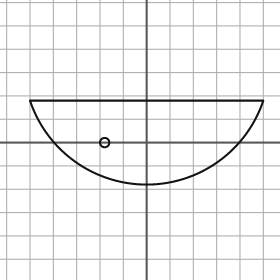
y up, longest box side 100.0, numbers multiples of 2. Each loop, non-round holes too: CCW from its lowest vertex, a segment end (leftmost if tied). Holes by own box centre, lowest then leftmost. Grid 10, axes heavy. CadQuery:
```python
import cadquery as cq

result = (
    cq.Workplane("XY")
    .moveTo(-50.0, 18.0)
    .threePointArc((0.0, -18.0), (50.0, 18.0))
    .close()
    .moveTo(-18.0, 0.0)
    .circle(2.0)
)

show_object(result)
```